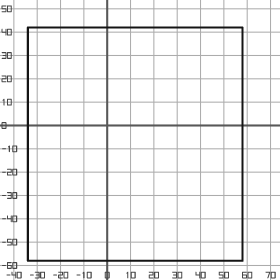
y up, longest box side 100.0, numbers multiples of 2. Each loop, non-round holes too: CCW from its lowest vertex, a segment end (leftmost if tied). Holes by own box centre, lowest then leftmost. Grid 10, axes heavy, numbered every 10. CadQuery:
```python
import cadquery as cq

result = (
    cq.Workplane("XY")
    .moveTo(-34.0, -58.0)
    .lineTo(58.0, -58.0)
    .lineTo(58.0, 42.0)
    .lineTo(-34.0, 42.0)
    .close()
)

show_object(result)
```